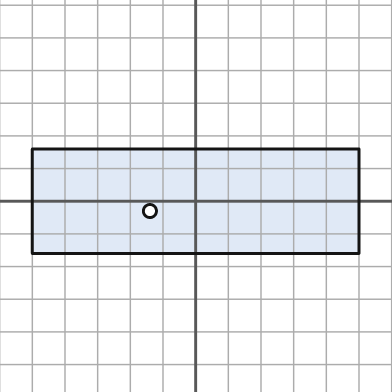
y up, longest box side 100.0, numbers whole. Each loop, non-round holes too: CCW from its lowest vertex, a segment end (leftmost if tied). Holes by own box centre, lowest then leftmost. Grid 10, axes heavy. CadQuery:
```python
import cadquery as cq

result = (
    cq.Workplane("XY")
    .moveTo(-50.0, -16.0)
    .lineTo(50.0, -16.0)
    .lineTo(50.0, 16.0)
    .lineTo(-50.0, 16.0)
    .close()
    .moveTo(-14.0, -3.0)
    .circle(2.0)
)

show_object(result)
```